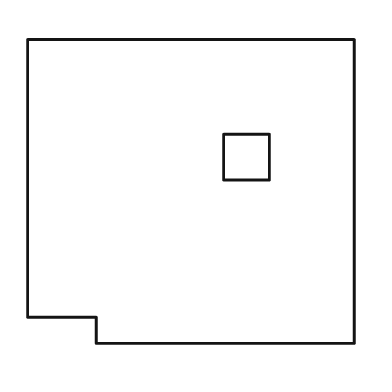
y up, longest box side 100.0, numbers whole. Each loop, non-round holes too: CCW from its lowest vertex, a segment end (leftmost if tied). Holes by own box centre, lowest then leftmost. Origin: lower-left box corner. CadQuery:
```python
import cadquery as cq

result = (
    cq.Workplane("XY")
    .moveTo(21.0, 0.0)
    .lineTo(100.0, 0.0)
    .lineTo(100.0, 93.0)
    .lineTo(0.0, 93.0)
    .lineTo(0.0, 8.0)
    .lineTo(21.0, 8.0)
    .close()
    .moveTo(60.0, 50.0)
    .lineTo(74.0, 50.0)
    .lineTo(74.0, 64.0)
    .lineTo(60.0, 64.0)
    .close()
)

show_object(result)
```